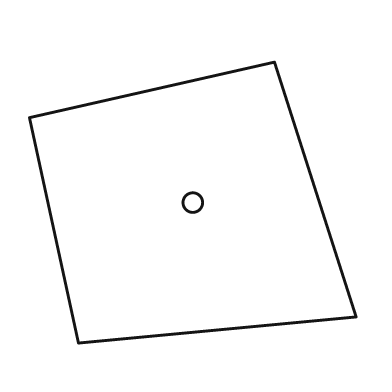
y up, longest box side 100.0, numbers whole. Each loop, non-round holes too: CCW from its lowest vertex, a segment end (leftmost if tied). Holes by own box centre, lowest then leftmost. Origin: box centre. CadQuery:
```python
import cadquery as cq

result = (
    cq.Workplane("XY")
    .moveTo(-35.0, -43.0)
    .lineTo(50.0, -35.0)
    .lineTo(25.0, 43.0)
    .lineTo(-50.0, 26.0)
    .close()
    .moveTo(0.0, 0.0)
    .circle(3.0)
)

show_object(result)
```